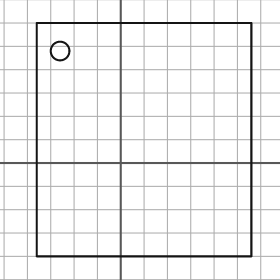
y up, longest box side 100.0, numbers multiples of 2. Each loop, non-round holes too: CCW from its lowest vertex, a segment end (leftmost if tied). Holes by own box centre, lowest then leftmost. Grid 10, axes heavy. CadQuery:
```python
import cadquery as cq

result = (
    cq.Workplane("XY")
    .moveTo(-36.0, -40.0)
    .lineTo(56.0, -40.0)
    .lineTo(56.0, 60.0)
    .lineTo(-36.0, 60.0)
    .close()
    .moveTo(-26.0, 48.0)
    .circle(4.0)
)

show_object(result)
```